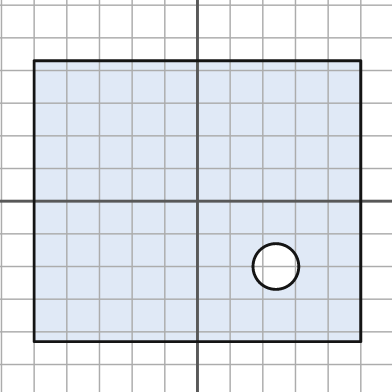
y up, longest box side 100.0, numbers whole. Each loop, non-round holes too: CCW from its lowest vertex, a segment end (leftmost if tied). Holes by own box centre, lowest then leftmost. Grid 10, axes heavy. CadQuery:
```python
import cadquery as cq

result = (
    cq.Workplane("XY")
    .moveTo(-50.0, -43.0)
    .lineTo(50.0, -43.0)
    .lineTo(50.0, 43.0)
    .lineTo(-50.0, 43.0)
    .close()
    .moveTo(24.0, -20.0)
    .circle(7.0)
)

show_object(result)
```